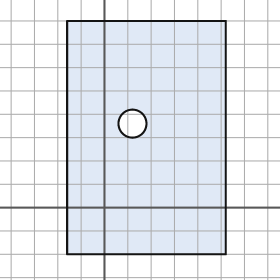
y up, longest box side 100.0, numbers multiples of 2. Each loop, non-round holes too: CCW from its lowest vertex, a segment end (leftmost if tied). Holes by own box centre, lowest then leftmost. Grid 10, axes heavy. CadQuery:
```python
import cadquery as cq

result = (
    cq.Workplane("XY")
    .moveTo(-16.0, -20.0)
    .lineTo(52.0, -20.0)
    .lineTo(52.0, 80.0)
    .lineTo(-16.0, 80.0)
    .close()
    .moveTo(12.0, 36.0)
    .circle(6.0)
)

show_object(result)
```